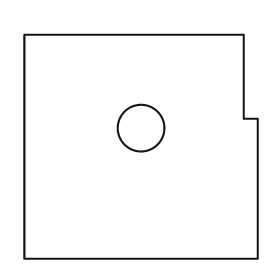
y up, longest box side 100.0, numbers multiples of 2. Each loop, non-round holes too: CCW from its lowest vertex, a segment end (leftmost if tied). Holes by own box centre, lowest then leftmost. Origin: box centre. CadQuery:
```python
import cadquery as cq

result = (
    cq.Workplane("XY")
    .moveTo(-50.0, -48.0)
    .lineTo(50.0, -48.0)
    .lineTo(50.0, 12.0)
    .lineTo(44.0, 12.0)
    .lineTo(44.0, 48.0)
    .lineTo(-50.0, 48.0)
    .close()
    .moveTo(0.0, 8.0)
    .circle(10.0)
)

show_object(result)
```